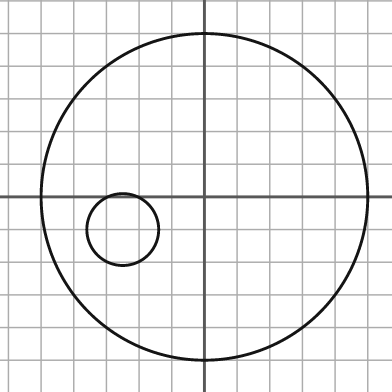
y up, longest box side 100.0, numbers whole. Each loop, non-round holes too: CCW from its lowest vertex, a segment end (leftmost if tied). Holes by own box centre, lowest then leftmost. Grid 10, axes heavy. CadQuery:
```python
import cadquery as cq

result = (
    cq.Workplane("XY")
    .moveTo(0.0, 0.0)
    .circle(50.0)
    .moveTo(-25.0, -10.0)
    .circle(11.0)
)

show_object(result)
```